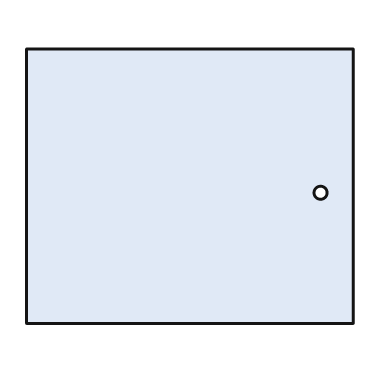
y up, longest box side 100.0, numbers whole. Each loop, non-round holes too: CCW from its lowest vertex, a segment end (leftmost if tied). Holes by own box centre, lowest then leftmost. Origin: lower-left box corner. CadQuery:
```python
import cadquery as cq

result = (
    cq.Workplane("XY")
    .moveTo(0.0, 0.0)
    .lineTo(100.0, 0.0)
    .lineTo(100.0, 84.0)
    .lineTo(0.0, 84.0)
    .close()
    .moveTo(90.0, 40.0)
    .circle(2.0)
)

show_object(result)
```